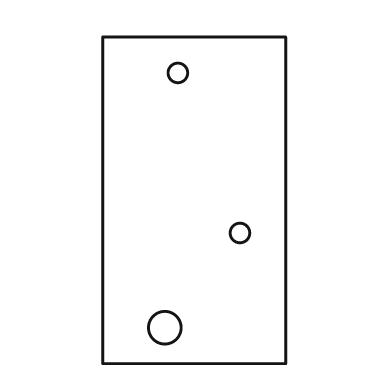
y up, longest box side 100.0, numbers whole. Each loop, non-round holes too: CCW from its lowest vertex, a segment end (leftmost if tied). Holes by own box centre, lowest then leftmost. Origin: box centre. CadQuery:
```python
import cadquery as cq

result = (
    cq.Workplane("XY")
    .moveTo(-28.0, -50.0)
    .lineTo(28.0, -50.0)
    .lineTo(28.0, 50.0)
    .lineTo(-28.0, 50.0)
    .close()
    .moveTo(-9.0, -39.0)
    .circle(5.0)
    .moveTo(14.0, -10.0)
    .circle(3.0)
    .moveTo(-5.0, 39.0)
    .circle(3.0)
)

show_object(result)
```